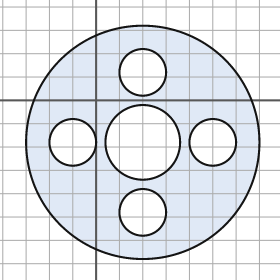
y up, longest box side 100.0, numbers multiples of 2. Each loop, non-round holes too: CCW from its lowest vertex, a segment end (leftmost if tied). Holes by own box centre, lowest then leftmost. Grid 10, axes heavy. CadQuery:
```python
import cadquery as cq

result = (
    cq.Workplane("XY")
    .moveTo(20.0, -18.0)
    .circle(50.0)
    .moveTo(20.0, -48.0)
    .circle(10.0)
    .moveTo(-10.0, -18.0)
    .circle(10.0)
    .moveTo(20.0, -18.0)
    .circle(16.0)
    .moveTo(50.0, -18.0)
    .circle(10.0)
    .moveTo(20.0, 12.0)
    .circle(10.0)
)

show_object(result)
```